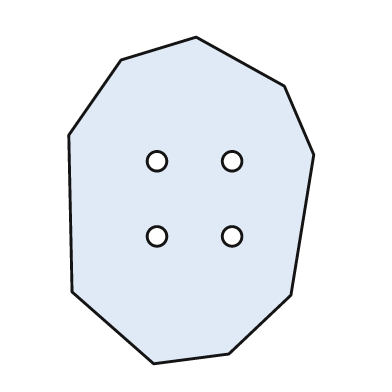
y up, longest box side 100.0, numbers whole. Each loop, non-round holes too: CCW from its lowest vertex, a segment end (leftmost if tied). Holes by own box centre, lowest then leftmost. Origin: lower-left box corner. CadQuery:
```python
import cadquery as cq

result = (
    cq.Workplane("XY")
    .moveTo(26.0, 0.0)
    .lineTo(49.0, 3.0)
    .lineTo(68.0, 21.0)
    .lineTo(75.0, 64.0)
    .lineTo(66.0, 85.0)
    .lineTo(39.0, 100.0)
    .lineTo(16.0, 93.0)
    .lineTo(0.0, 70.0)
    .lineTo(1.0, 22.0)
    .close()
    .moveTo(27.0, 39.0)
    .circle(3.0)
    .moveTo(50.0, 39.0)
    .circle(3.0)
    .moveTo(27.0, 62.0)
    .circle(3.0)
    .moveTo(50.0, 62.0)
    .circle(3.0)
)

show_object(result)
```